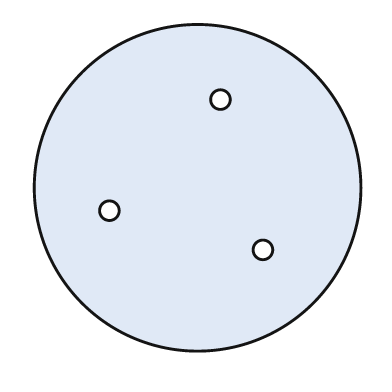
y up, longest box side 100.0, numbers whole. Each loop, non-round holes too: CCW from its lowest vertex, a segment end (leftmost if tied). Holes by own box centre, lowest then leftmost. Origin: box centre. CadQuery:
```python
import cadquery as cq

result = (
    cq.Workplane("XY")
    .moveTo(0.0, 0.0)
    .circle(50.0)
    .moveTo(20.0, -19.0)
    .circle(3.0)
    .moveTo(-27.0, -7.0)
    .circle(3.0)
    .moveTo(7.0, 27.0)
    .circle(3.0)
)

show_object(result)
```